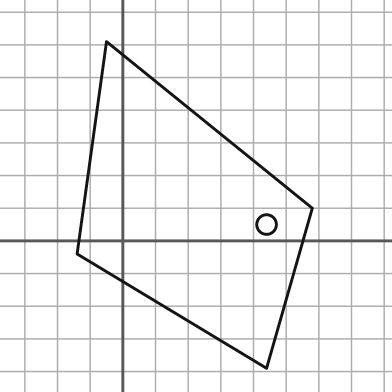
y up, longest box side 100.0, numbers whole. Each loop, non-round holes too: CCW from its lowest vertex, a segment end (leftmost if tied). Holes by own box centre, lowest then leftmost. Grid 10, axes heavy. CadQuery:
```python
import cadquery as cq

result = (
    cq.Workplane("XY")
    .moveTo(44.0, -39.0)
    .lineTo(58.0, 10.0)
    .lineTo(-5.0, 61.0)
    .lineTo(-14.0, -4.0)
    .close()
    .moveTo(44.0, 5.0)
    .circle(3.0)
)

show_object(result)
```